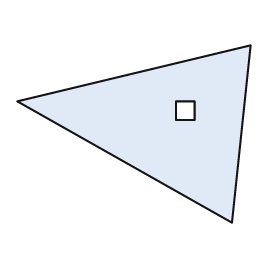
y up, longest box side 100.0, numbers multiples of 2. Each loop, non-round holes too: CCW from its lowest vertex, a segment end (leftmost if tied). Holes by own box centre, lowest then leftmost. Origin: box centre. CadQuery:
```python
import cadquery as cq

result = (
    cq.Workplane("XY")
    .moveTo(42.0, -38.0)
    .lineTo(50.0, 38.0)
    .lineTo(-50.0, 14.0)
    .close()
    .moveTo(18.0, 6.0)
    .lineTo(26.0, 6.0)
    .lineTo(26.0, 14.0)
    .lineTo(18.0, 14.0)
    .close()
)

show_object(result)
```